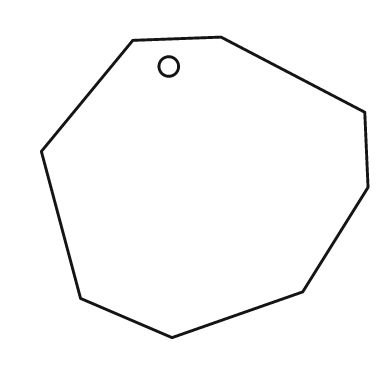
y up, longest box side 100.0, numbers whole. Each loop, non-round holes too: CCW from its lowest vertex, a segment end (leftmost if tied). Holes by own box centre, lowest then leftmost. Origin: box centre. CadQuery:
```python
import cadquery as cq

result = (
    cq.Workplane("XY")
    .moveTo(-10.0, -46.0)
    .lineTo(30.0, -32.0)
    .lineTo(50.0, 0.0)
    .lineTo(49.0, 23.0)
    .lineTo(5.0, 46.0)
    .lineTo(-22.0, 45.0)
    .lineTo(-50.0, 11.0)
    .lineTo(-38.0, -34.0)
    .close()
    .moveTo(-11.0, 37.0)
    .circle(3.0)
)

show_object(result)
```